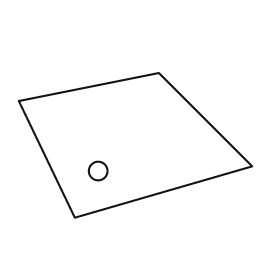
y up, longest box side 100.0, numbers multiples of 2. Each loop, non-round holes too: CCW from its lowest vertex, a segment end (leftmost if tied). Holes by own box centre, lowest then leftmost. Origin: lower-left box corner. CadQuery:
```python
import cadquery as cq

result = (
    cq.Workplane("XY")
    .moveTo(24.0, 0.0)
    .lineTo(100.0, 22.0)
    .lineTo(60.0, 62.0)
    .lineTo(0.0, 50.0)
    .close()
    .moveTo(34.0, 20.0)
    .circle(4.0)
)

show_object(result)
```